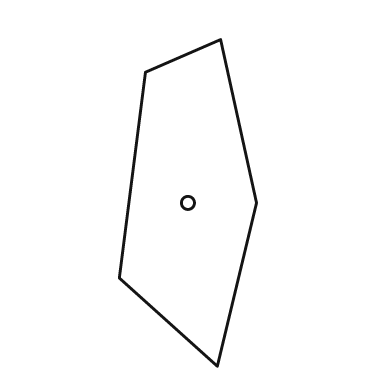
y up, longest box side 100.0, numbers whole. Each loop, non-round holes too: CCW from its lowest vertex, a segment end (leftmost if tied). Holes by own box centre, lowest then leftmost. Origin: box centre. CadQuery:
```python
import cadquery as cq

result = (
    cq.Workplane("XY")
    .moveTo(9.0, -50.0)
    .lineTo(21.0, 0.0)
    .lineTo(10.0, 50.0)
    .lineTo(-13.0, 40.0)
    .lineTo(-21.0, -23.0)
    .close()
    .moveTo(0.0, 0.0)
    .circle(2.0)
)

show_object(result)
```